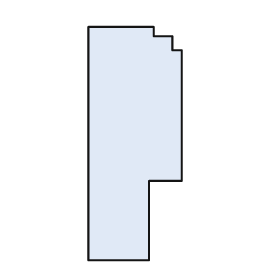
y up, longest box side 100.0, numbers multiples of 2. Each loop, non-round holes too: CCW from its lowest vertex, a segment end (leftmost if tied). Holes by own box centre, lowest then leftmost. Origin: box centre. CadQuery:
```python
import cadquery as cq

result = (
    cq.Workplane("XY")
    .moveTo(-20.0, -50.0)
    .lineTo(6.0, -50.0)
    .lineTo(6.0, -16.0)
    .lineTo(20.0, -16.0)
    .lineTo(20.0, 40.0)
    .lineTo(16.0, 40.0)
    .lineTo(16.0, 46.0)
    .lineTo(8.0, 46.0)
    .lineTo(8.0, 50.0)
    .lineTo(-20.0, 50.0)
    .close()
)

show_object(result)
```